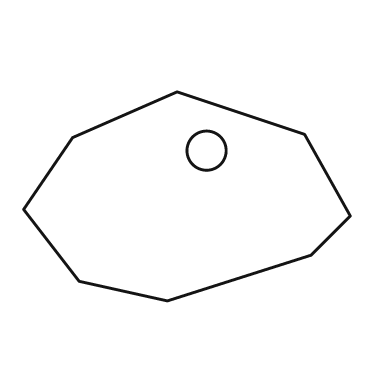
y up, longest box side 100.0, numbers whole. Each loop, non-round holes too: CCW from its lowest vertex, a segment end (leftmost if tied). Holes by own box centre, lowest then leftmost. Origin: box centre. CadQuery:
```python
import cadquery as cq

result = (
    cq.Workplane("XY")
    .moveTo(-6.0, -32.0)
    .lineTo(38.0, -18.0)
    .lineTo(50.0, -6.0)
    .lineTo(36.0, 19.0)
    .lineTo(-3.0, 32.0)
    .lineTo(-35.0, 18.0)
    .lineTo(-50.0, -4.0)
    .lineTo(-33.0, -26.0)
    .close()
    .moveTo(6.0, 14.0)
    .circle(6.0)
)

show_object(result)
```